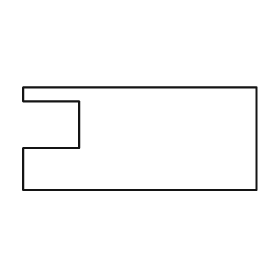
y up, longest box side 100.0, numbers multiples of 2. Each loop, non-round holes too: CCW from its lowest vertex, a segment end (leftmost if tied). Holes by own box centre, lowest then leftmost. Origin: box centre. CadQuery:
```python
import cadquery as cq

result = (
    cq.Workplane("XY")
    .moveTo(-50.0, -22.0)
    .lineTo(50.0, -22.0)
    .lineTo(50.0, 22.0)
    .lineTo(-50.0, 22.0)
    .lineTo(-50.0, 16.0)
    .lineTo(-26.0, 16.0)
    .lineTo(-26.0, -4.0)
    .lineTo(-50.0, -4.0)
    .close()
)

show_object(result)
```